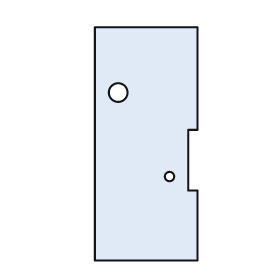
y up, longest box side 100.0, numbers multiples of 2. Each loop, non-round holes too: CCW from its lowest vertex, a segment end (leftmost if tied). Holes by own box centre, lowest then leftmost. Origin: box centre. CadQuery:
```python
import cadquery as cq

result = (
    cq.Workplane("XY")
    .moveTo(-22.0, -50.0)
    .lineTo(22.0, -50.0)
    .lineTo(22.0, -20.0)
    .lineTo(18.0, -20.0)
    .lineTo(18.0, 6.0)
    .lineTo(22.0, 6.0)
    .lineTo(22.0, 50.0)
    .lineTo(-22.0, 50.0)
    .close()
    .moveTo(10.0, -14.0)
    .circle(2.0)
    .moveTo(-12.0, 22.0)
    .circle(4.0)
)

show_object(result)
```